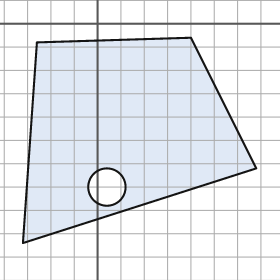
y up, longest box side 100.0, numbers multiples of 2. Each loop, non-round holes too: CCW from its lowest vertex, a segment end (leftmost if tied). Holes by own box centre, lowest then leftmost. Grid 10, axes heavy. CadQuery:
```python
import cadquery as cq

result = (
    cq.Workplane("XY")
    .moveTo(-32.0, -94.0)
    .lineTo(68.0, -62.0)
    .lineTo(40.0, -6.0)
    .lineTo(-26.0, -8.0)
    .close()
    .moveTo(4.0, -70.0)
    .circle(8.0)
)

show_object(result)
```